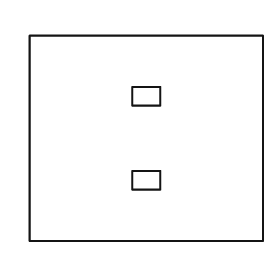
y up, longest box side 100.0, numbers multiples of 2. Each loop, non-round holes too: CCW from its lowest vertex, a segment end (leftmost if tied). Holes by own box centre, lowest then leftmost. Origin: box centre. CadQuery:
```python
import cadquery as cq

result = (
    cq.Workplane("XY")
    .moveTo(-50.0, -44.0)
    .lineTo(50.0, -44.0)
    .lineTo(50.0, 44.0)
    .lineTo(-50.0, 44.0)
    .close()
    .moveTo(-6.0, -22.0)
    .lineTo(6.0, -22.0)
    .lineTo(6.0, -14.0)
    .lineTo(-6.0, -14.0)
    .close()
    .moveTo(-6.0, 14.0)
    .lineTo(6.0, 14.0)
    .lineTo(6.0, 22.0)
    .lineTo(-6.0, 22.0)
    .close()
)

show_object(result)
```